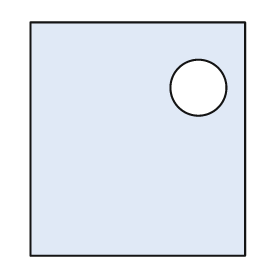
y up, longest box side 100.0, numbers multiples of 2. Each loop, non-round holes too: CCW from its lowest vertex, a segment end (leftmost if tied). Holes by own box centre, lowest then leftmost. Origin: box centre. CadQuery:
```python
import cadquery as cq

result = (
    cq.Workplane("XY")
    .moveTo(-46.0, -50.0)
    .lineTo(46.0, -50.0)
    .lineTo(46.0, 50.0)
    .lineTo(-46.0, 50.0)
    .close()
    .moveTo(26.0, 22.0)
    .circle(12.0)
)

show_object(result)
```